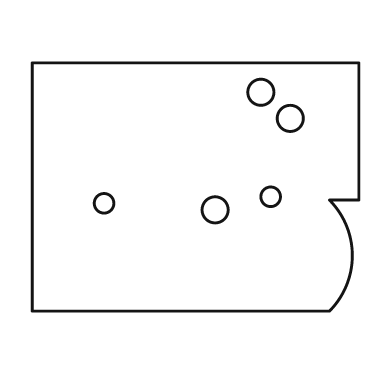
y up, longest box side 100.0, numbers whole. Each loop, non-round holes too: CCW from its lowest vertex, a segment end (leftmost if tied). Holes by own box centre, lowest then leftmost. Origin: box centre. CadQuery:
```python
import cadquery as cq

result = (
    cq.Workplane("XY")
    .moveTo(-50.0, -38.0)
    .lineTo(41.0, -38.0)
    .threePointArc((48.0, -21.0), (41.0, -4.0))
    .lineTo(50.0, -4.0)
    .lineTo(50.0, 38.0)
    .lineTo(-50.0, 38.0)
    .close()
    .moveTo(6.0, -7.0)
    .circle(4.0)
    .moveTo(-28.0, -5.0)
    .circle(3.0)
    .moveTo(23.0, -3.0)
    .circle(3.0)
    .moveTo(29.0, 21.0)
    .circle(4.0)
    .moveTo(20.0, 29.0)
    .circle(4.0)
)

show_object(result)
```